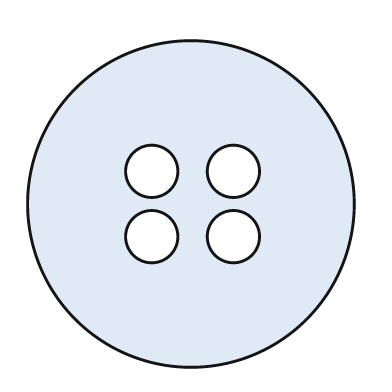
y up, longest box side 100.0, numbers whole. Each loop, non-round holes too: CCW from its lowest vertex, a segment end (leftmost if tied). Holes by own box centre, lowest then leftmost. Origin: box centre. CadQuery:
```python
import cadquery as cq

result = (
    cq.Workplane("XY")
    .moveTo(0.0, 0.0)
    .circle(50.0)
    .moveTo(-12.0, -10.0)
    .circle(8.0)
    .moveTo(13.0, -10.0)
    .circle(8.0)
    .moveTo(-12.0, 10.0)
    .circle(8.0)
    .moveTo(13.0, 10.0)
    .circle(8.0)
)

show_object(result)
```